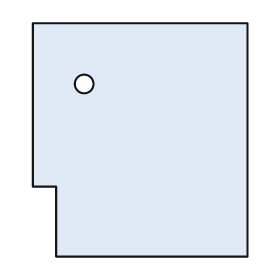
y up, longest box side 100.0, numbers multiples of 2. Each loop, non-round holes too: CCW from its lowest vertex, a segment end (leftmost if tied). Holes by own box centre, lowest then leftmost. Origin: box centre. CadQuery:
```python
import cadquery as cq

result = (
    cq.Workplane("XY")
    .moveTo(-36.0, -50.0)
    .lineTo(46.0, -50.0)
    .lineTo(46.0, 50.0)
    .lineTo(-46.0, 50.0)
    .lineTo(-46.0, -20.0)
    .lineTo(-36.0, -20.0)
    .close()
    .moveTo(-24.0, 24.0)
    .circle(4.0)
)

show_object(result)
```